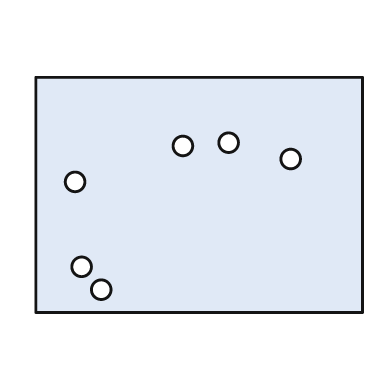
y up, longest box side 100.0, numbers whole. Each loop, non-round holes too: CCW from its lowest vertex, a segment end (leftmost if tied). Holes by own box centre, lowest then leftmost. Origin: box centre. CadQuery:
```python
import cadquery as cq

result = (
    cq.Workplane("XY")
    .moveTo(-50.0, -36.0)
    .lineTo(50.0, -36.0)
    .lineTo(50.0, 36.0)
    .lineTo(-50.0, 36.0)
    .close()
    .moveTo(-30.0, -29.0)
    .circle(3.0)
    .moveTo(-36.0, -22.0)
    .circle(3.0)
    .moveTo(-38.0, 4.0)
    .circle(3.0)
    .moveTo(28.0, 11.0)
    .circle(3.0)
    .moveTo(-5.0, 15.0)
    .circle(3.0)
    .moveTo(9.0, 16.0)
    .circle(3.0)
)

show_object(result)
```